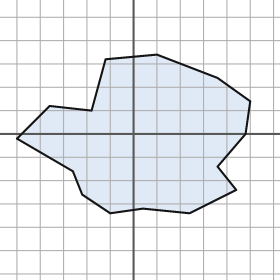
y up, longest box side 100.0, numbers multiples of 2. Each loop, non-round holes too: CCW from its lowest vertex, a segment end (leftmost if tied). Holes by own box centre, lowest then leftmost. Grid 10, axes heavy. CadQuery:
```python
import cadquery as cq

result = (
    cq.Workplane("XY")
    .moveTo(-10.0, -34.0)
    .lineTo(4.0, -32.0)
    .lineTo(24.0, -34.0)
    .lineTo(44.0, -24.0)
    .lineTo(36.0, -14.0)
    .lineTo(48.0, 0.0)
    .lineTo(50.0, 14.0)
    .lineTo(36.0, 24.0)
    .lineTo(10.0, 34.0)
    .lineTo(-12.0, 32.0)
    .lineTo(-18.0, 10.0)
    .lineTo(-36.0, 12.0)
    .lineTo(-50.0, -2.0)
    .lineTo(-26.0, -16.0)
    .lineTo(-22.0, -26.0)
    .close()
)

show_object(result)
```